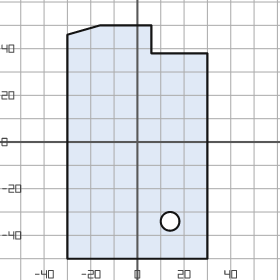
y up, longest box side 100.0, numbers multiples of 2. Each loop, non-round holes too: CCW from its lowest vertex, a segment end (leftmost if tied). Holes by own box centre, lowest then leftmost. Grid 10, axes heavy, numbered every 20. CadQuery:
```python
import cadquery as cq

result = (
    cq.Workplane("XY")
    .moveTo(-30.0, -50.0)
    .lineTo(30.0, -50.0)
    .lineTo(30.0, 38.0)
    .lineTo(6.0, 38.0)
    .lineTo(6.0, 50.0)
    .lineTo(-16.0, 50.0)
    .lineTo(-30.0, 46.0)
    .close()
    .moveTo(14.0, -34.0)
    .circle(4.0)
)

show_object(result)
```